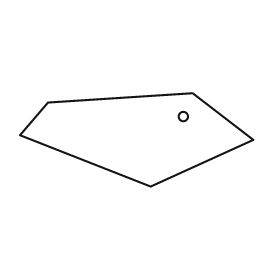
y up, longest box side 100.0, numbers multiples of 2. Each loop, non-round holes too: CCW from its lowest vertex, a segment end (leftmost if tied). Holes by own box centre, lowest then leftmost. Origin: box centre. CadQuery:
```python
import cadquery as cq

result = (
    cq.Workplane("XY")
    .moveTo(6.0, -20.0)
    .lineTo(50.0, 0.0)
    .lineTo(24.0, 20.0)
    .lineTo(-38.0, 16.0)
    .lineTo(-50.0, 2.0)
    .close()
    .moveTo(20.0, 10.0)
    .circle(2.0)
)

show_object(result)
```